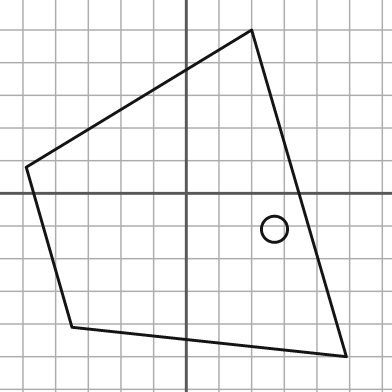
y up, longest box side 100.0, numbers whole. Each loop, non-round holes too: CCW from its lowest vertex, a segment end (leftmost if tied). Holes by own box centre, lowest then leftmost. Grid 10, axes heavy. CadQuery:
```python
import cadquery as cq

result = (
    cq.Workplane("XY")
    .moveTo(49.0, -50.0)
    .lineTo(20.0, 50.0)
    .lineTo(-49.0, 8.0)
    .lineTo(-35.0, -41.0)
    .close()
    .moveTo(27.0, -11.0)
    .circle(4.0)
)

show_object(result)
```